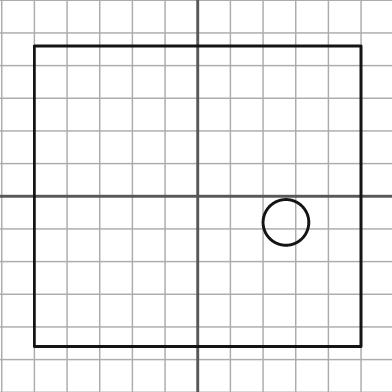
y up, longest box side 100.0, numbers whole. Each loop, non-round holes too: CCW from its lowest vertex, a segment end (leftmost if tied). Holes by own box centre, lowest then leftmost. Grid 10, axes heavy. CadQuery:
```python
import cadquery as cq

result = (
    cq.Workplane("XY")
    .moveTo(-50.0, -46.0)
    .lineTo(50.0, -46.0)
    .lineTo(50.0, 46.0)
    .lineTo(-50.0, 46.0)
    .close()
    .moveTo(27.0, -8.0)
    .circle(7.0)
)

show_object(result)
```